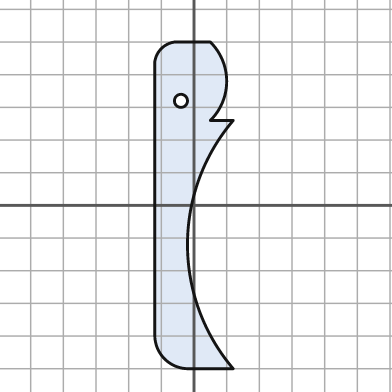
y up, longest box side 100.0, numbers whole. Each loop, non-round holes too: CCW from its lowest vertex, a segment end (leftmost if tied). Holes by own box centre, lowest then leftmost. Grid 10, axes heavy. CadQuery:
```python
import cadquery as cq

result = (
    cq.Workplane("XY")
    .moveTo(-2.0, -50.0)
    .lineTo(12.0, -50.0)
    .threePointArc((-2.0, -12.0), (12.0, 26.0))
    .lineTo(5.0, 26.0)
    .threePointArc((10.0, 38.0), (5.0, 50.0))
    .lineTo(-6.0, 50.0)
    .threePointArc((-10.0, 48.0), (-12.0, 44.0))
    .lineTo(-12.0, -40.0)
    .threePointArc((-9.0, -47.0), (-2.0, -50.0))
    .close()
    .moveTo(-4.0, 32.0)
    .circle(2.0)
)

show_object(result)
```